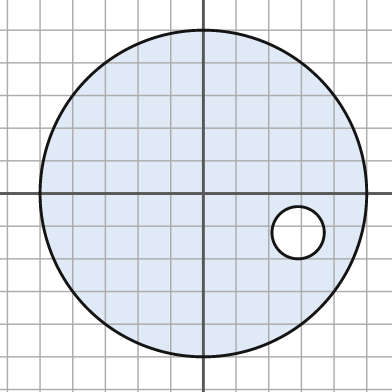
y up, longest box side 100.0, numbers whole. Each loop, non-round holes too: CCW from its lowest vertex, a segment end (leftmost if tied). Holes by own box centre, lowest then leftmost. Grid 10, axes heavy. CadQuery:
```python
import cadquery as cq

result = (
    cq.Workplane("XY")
    .moveTo(0.0, 0.0)
    .circle(50.0)
    .moveTo(29.0, -12.0)
    .circle(8.0)
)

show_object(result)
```